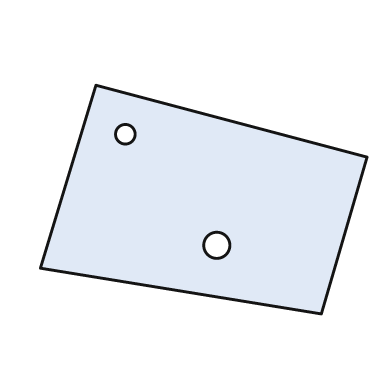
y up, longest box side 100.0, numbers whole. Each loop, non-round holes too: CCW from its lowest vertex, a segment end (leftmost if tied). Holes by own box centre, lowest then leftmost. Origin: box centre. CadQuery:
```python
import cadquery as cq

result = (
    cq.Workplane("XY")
    .moveTo(36.0, -35.0)
    .lineTo(50.0, 13.0)
    .lineTo(-33.0, 35.0)
    .lineTo(-50.0, -21.0)
    .close()
    .moveTo(4.0, -14.0)
    .circle(4.0)
    .moveTo(-24.0, 20.0)
    .circle(3.0)
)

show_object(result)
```